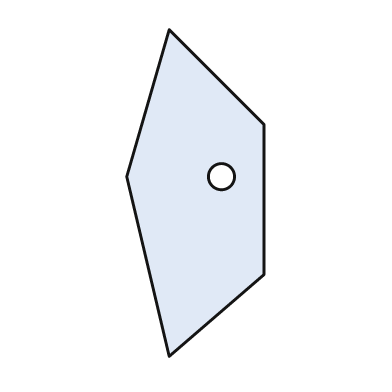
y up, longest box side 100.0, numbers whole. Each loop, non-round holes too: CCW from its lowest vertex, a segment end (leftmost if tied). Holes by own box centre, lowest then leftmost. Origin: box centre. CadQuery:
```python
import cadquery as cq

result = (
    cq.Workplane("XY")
    .moveTo(-8.0, -50.0)
    .lineTo(21.0, -25.0)
    .lineTo(21.0, 21.0)
    .lineTo(-8.0, 50.0)
    .lineTo(-21.0, 5.0)
    .close()
    .moveTo(8.0, 5.0)
    .circle(4.0)
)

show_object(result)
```